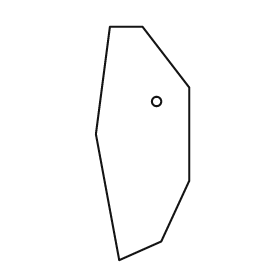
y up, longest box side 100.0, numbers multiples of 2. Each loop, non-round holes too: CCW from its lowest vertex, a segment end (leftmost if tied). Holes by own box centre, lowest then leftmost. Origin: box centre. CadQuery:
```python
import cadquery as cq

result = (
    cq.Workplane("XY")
    .moveTo(-10.0, -50.0)
    .lineTo(8.0, -42.0)
    .lineTo(20.0, -16.0)
    .lineTo(20.0, 24.0)
    .lineTo(0.0, 50.0)
    .lineTo(-14.0, 50.0)
    .lineTo(-20.0, 4.0)
    .close()
    .moveTo(6.0, 18.0)
    .circle(2.0)
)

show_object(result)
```